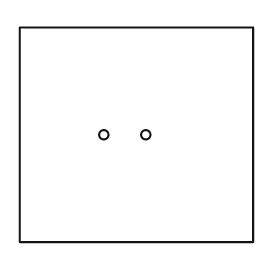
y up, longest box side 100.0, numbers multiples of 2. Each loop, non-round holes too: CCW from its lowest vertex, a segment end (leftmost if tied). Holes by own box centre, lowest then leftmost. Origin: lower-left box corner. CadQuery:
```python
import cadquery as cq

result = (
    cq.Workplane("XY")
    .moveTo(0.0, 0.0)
    .lineTo(100.0, 0.0)
    .lineTo(100.0, 92.0)
    .lineTo(0.0, 92.0)
    .close()
    .moveTo(36.0, 46.0)
    .circle(2.0)
    .moveTo(54.0, 46.0)
    .circle(2.0)
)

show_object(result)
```